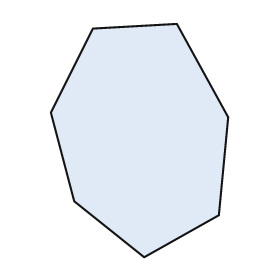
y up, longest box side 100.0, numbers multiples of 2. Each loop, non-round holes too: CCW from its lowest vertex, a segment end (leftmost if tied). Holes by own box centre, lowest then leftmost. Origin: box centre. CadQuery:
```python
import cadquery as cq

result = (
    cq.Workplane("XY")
    .moveTo(2.0, -50.0)
    .lineTo(34.0, -32.0)
    .lineTo(38.0, 10.0)
    .lineTo(16.0, 50.0)
    .lineTo(-20.0, 48.0)
    .lineTo(-38.0, 12.0)
    .lineTo(-28.0, -26.0)
    .close()
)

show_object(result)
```